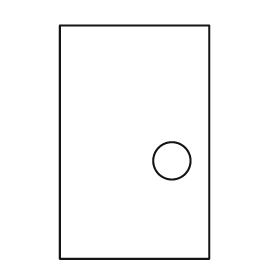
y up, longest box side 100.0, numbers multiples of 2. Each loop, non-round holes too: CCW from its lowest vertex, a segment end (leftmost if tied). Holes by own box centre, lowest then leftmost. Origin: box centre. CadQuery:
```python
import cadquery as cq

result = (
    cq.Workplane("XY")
    .moveTo(-32.0, -50.0)
    .lineTo(32.0, -50.0)
    .lineTo(32.0, 50.0)
    .lineTo(-32.0, 50.0)
    .close()
    .moveTo(16.0, -8.0)
    .circle(8.0)
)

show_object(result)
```